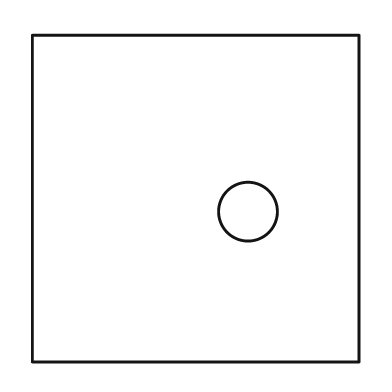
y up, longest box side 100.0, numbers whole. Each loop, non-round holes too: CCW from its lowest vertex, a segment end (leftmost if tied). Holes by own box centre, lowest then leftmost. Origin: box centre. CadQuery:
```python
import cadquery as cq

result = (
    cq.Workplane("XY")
    .moveTo(-50.0, -50.0)
    .lineTo(50.0, -50.0)
    .lineTo(50.0, 50.0)
    .lineTo(-50.0, 50.0)
    .close()
    .moveTo(16.0, -4.0)
    .circle(9.0)
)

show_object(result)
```